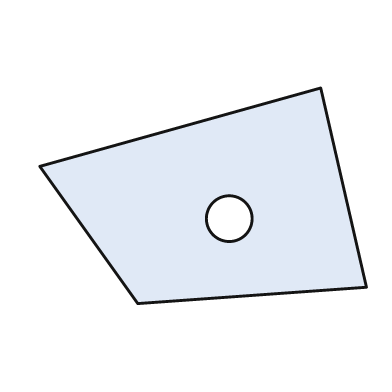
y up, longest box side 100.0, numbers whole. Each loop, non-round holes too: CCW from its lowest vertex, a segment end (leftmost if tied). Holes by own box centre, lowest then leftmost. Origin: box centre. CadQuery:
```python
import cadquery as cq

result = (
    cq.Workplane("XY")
    .moveTo(-20.0, -33.0)
    .lineTo(50.0, -28.0)
    .lineTo(36.0, 33.0)
    .lineTo(-50.0, 9.0)
    .close()
    .moveTo(8.0, -7.0)
    .circle(7.0)
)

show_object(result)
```